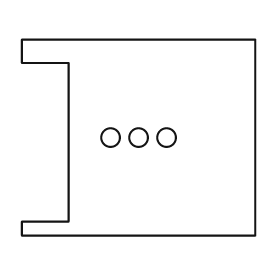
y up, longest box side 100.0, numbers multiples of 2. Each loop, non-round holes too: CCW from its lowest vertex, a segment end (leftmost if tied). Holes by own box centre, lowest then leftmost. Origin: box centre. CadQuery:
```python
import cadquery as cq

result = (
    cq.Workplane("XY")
    .moveTo(-50.0, -42.0)
    .lineTo(50.0, -42.0)
    .lineTo(50.0, 42.0)
    .lineTo(-50.0, 42.0)
    .lineTo(-50.0, 32.0)
    .lineTo(-30.0, 32.0)
    .lineTo(-30.0, -36.0)
    .lineTo(-50.0, -36.0)
    .close()
    .moveTo(-12.0, 0.0)
    .circle(4.0)
    .moveTo(0.0, 0.0)
    .circle(4.0)
    .moveTo(12.0, 0.0)
    .circle(4.0)
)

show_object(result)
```